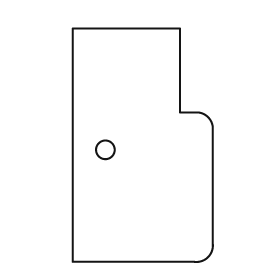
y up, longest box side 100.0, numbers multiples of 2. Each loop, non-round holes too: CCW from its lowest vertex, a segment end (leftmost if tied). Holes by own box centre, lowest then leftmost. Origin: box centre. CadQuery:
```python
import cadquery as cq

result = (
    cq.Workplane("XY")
    .moveTo(-30.0, -50.0)
    .lineTo(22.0, -50.0)
    .threePointArc((28.0, -48.0), (30.0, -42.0))
    .lineTo(30.0, 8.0)
    .threePointArc((28.0, 12.0), (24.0, 14.0))
    .lineTo(16.0, 14.0)
    .lineTo(16.0, 50.0)
    .lineTo(-30.0, 50.0)
    .close()
    .moveTo(-16.0, -2.0)
    .circle(4.0)
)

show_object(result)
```